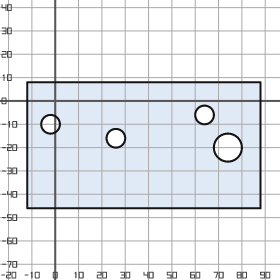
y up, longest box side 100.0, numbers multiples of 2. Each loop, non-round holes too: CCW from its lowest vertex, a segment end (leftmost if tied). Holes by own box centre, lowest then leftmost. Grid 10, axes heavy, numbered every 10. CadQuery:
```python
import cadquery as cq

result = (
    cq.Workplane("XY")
    .moveTo(-12.0, -46.0)
    .lineTo(88.0, -46.0)
    .lineTo(88.0, 8.0)
    .lineTo(-12.0, 8.0)
    .close()
    .moveTo(74.0, -20.0)
    .circle(6.0)
    .moveTo(26.0, -16.0)
    .circle(4.0)
    .moveTo(-2.0, -10.0)
    .circle(4.0)
    .moveTo(64.0, -6.0)
    .circle(4.0)
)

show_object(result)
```